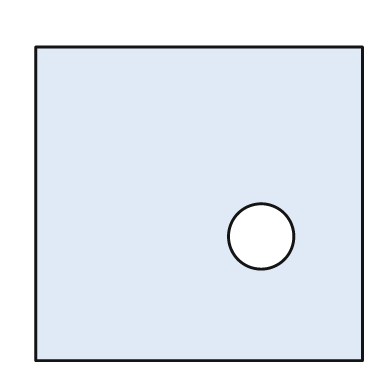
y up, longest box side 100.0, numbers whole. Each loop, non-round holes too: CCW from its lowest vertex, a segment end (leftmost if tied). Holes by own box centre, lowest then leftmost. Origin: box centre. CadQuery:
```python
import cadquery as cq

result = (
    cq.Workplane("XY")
    .moveTo(-50.0, -48.0)
    .lineTo(50.0, -48.0)
    .lineTo(50.0, 48.0)
    .lineTo(-50.0, 48.0)
    .close()
    .moveTo(19.0, -10.0)
    .circle(10.0)
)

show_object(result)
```